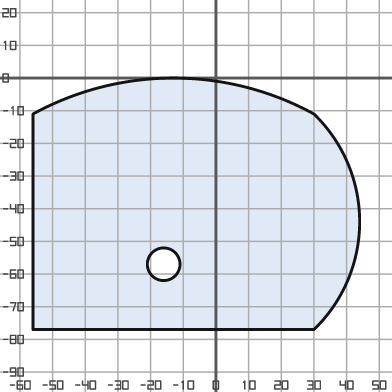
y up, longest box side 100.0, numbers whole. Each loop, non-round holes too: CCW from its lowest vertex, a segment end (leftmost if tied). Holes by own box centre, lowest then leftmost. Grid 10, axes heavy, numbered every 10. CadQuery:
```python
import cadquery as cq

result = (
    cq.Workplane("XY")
    .moveTo(-56.0, -77.0)
    .lineTo(30.0, -77.0)
    .threePointArc((44.0, -44.0), (30.0, -11.0))
    .threePointArc((-13.0, 0.0), (-56.0, -11.0))
    .close()
    .moveTo(-16.0, -57.0)
    .circle(5.0)
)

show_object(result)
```